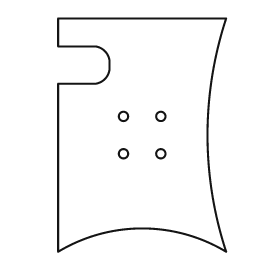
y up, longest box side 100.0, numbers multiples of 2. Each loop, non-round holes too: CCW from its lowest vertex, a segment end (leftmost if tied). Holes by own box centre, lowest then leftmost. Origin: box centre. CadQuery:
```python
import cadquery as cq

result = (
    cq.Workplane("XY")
    .moveTo(-36.0, -50.0)
    .threePointArc((0.0, -40.0), (36.0, -50.0))
    .threePointArc((28.0, 0.0), (36.0, 50.0))
    .lineTo(-36.0, 50.0)
    .lineTo(-36.0, 38.0)
    .lineTo(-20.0, 38.0)
    .threePointArc((-16.0, 36.0), (-14.0, 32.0))
    .lineTo(-14.0, 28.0)
    .threePointArc((-16.0, 24.0), (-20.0, 22.0))
    .lineTo(-36.0, 22.0)
    .close()
    .moveTo(-8.0, -8.0)
    .circle(2.0)
    .moveTo(8.0, -8.0)
    .circle(2.0)
    .moveTo(-8.0, 8.0)
    .circle(2.0)
    .moveTo(8.0, 8.0)
    .circle(2.0)
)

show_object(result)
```